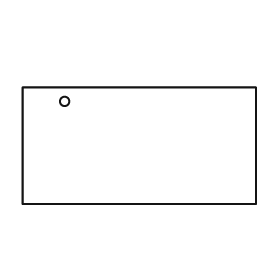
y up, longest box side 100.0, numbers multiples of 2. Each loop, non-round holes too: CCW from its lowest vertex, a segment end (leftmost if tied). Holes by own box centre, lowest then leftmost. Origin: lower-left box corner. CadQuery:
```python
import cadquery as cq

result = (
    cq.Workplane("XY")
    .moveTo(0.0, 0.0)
    .lineTo(100.0, 0.0)
    .lineTo(100.0, 50.0)
    .lineTo(0.0, 50.0)
    .close()
    .moveTo(18.0, 44.0)
    .circle(2.0)
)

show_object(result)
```